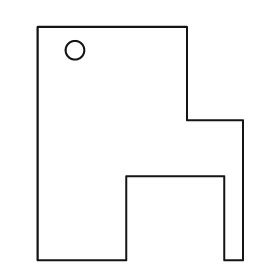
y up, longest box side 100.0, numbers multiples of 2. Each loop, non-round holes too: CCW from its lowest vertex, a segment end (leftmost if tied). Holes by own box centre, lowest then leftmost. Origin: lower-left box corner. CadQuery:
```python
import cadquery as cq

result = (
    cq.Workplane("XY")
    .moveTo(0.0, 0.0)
    .lineTo(38.0, 0.0)
    .lineTo(38.0, 36.0)
    .lineTo(80.0, 36.0)
    .lineTo(80.0, 0.0)
    .lineTo(88.0, 0.0)
    .lineTo(88.0, 60.0)
    .lineTo(64.0, 60.0)
    .lineTo(64.0, 100.0)
    .lineTo(0.0, 100.0)
    .close()
    .moveTo(16.0, 90.0)
    .circle(4.0)
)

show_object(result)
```